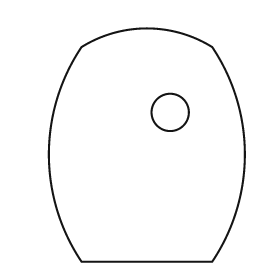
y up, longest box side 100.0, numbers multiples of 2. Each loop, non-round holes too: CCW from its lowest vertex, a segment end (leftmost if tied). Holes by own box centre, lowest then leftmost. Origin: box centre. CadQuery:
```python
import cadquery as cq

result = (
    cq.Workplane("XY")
    .moveTo(-28.0, -50.0)
    .lineTo(28.0, -50.0)
    .threePointArc((42.0, -4.0), (28.0, 42.0))
    .threePointArc((0.0, 50.0), (-28.0, 42.0))
    .threePointArc((-42.0, -4.0), (-28.0, -50.0))
    .close()
    .moveTo(10.0, 14.0)
    .circle(8.0)
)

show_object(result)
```